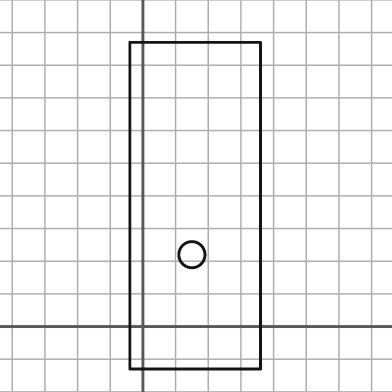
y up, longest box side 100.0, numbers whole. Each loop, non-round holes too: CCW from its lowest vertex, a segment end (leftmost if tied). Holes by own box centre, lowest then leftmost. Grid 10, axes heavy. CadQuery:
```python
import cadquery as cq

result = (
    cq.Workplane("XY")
    .moveTo(-4.0, -13.0)
    .lineTo(36.0, -13.0)
    .lineTo(36.0, 87.0)
    .lineTo(-4.0, 87.0)
    .close()
    .moveTo(15.0, 22.0)
    .circle(4.0)
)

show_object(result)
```